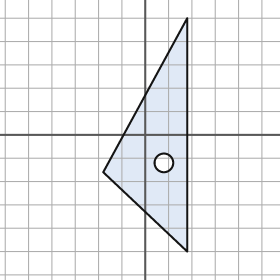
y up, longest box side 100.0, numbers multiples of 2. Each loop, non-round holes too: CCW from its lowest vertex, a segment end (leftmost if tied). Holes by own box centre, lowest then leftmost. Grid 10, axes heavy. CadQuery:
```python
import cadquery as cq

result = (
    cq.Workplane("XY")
    .moveTo(18.0, -50.0)
    .lineTo(18.0, 50.0)
    .lineTo(-18.0, -16.0)
    .close()
    .moveTo(8.0, -12.0)
    .circle(4.0)
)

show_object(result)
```